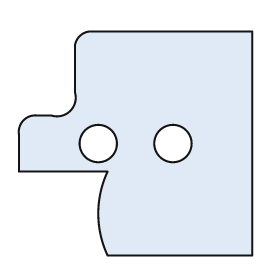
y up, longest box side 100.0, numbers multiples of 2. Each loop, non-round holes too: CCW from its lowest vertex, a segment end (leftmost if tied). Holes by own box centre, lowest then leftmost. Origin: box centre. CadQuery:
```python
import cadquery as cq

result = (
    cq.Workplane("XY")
    .moveTo(-12.0, -48.0)
    .lineTo(50.0, -48.0)
    .lineTo(50.0, 48.0)
    .lineTo(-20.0, 48.0)
    .threePointArc((-24.0, 46.0), (-26.0, 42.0))
    .lineTo(-26.0, 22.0)
    .threePointArc((-28.0, 14.0), (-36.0, 12.0))
    .lineTo(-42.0, 12.0)
    .threePointArc((-48.0, 10.0), (-50.0, 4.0))
    .lineTo(-50.0, -12.0)
    .lineTo(-12.0, -12.0)
    .threePointArc((-16.0, -30.0), (-12.0, -48.0))
    .close()
    .moveTo(-16.0, 0.0)
    .circle(8.0)
    .moveTo(16.0, 0.0)
    .circle(8.0)
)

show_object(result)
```